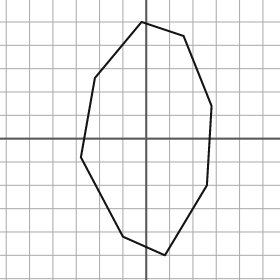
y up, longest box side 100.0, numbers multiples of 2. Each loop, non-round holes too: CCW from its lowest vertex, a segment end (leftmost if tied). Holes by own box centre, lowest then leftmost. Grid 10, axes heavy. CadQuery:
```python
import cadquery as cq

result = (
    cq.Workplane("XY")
    .moveTo(8.0, -50.0)
    .lineTo(26.0, -20.0)
    .lineTo(28.0, 14.0)
    .lineTo(16.0, 44.0)
    .lineTo(-2.0, 50.0)
    .lineTo(-22.0, 26.0)
    .lineTo(-28.0, -8.0)
    .lineTo(-10.0, -42.0)
    .close()
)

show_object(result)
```